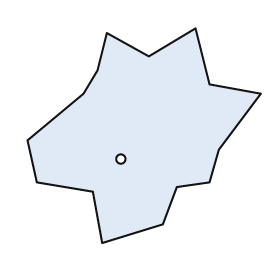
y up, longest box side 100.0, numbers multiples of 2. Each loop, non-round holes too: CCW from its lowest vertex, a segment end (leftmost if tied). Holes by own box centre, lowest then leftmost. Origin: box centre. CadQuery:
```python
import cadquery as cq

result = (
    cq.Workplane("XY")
    .moveTo(-18.0, -46.0)
    .lineTo(8.0, -38.0)
    .lineTo(14.0, -22.0)
    .lineTo(28.0, -20.0)
    .lineTo(32.0, -6.0)
    .lineTo(50.0, 18.0)
    .lineTo(28.0, 22.0)
    .lineTo(22.0, 46.0)
    .lineTo(2.0, 34.0)
    .lineTo(-16.0, 44.0)
    .lineTo(-20.0, 28.0)
    .lineTo(-26.0, 18.0)
    .lineTo(-50.0, -2.0)
    .lineTo(-46.0, -20.0)
    .lineTo(-22.0, -24.0)
    .close()
    .moveTo(-10.0, -10.0)
    .circle(2.0)
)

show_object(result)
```